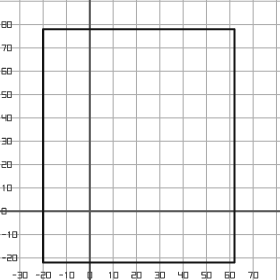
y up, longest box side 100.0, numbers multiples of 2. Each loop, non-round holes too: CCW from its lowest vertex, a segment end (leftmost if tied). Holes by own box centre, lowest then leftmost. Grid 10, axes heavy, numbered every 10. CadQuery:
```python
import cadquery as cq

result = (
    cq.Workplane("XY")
    .moveTo(-20.0, -22.0)
    .lineTo(62.0, -22.0)
    .lineTo(62.0, 78.0)
    .lineTo(-20.0, 78.0)
    .close()
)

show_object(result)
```